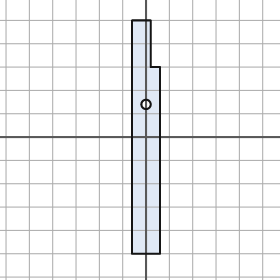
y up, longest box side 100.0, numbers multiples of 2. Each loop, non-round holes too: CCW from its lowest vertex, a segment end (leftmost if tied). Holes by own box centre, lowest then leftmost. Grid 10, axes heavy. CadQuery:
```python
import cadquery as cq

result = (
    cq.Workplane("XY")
    .moveTo(-6.0, -50.0)
    .lineTo(6.0, -50.0)
    .lineTo(6.0, 30.0)
    .lineTo(2.0, 30.0)
    .lineTo(2.0, 50.0)
    .lineTo(-6.0, 50.0)
    .close()
    .moveTo(0.0, 14.0)
    .circle(2.0)
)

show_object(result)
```